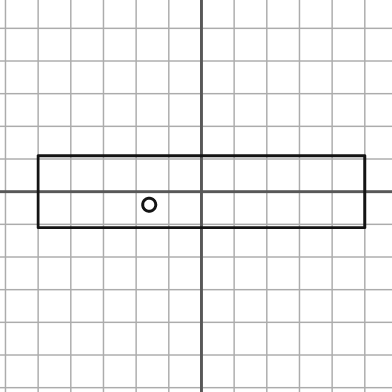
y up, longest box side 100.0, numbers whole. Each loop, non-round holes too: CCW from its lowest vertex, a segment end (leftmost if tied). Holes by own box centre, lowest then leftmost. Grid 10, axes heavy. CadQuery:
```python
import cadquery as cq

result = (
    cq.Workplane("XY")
    .moveTo(-50.0, -11.0)
    .lineTo(50.0, -11.0)
    .lineTo(50.0, 11.0)
    .lineTo(-50.0, 11.0)
    .close()
    .moveTo(-16.0, -4.0)
    .circle(2.0)
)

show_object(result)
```